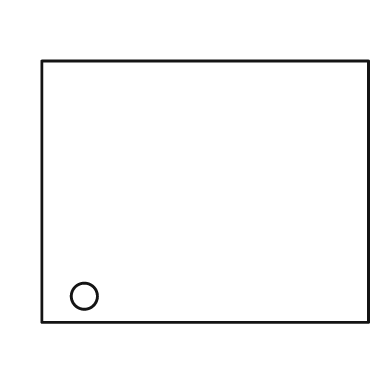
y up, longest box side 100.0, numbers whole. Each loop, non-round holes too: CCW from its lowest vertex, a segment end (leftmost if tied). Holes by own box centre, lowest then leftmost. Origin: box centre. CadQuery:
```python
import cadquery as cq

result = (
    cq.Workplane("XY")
    .moveTo(-50.0, -40.0)
    .lineTo(50.0, -40.0)
    .lineTo(50.0, 40.0)
    .lineTo(-50.0, 40.0)
    .close()
    .moveTo(-37.0, -32.0)
    .circle(4.0)
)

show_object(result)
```